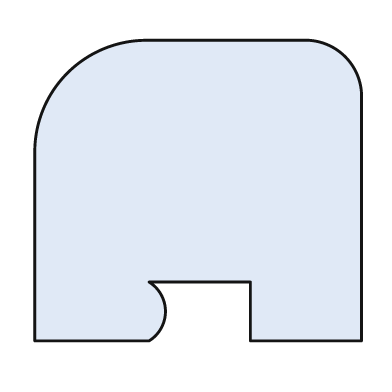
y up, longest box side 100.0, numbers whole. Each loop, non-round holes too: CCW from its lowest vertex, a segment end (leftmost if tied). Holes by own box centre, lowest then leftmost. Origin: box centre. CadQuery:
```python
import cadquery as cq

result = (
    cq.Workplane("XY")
    .moveTo(-50.0, -46.0)
    .lineTo(-15.0, -46.0)
    .threePointArc((-10.0, -37.0), (-15.0, -28.0))
    .lineTo(16.0, -28.0)
    .lineTo(16.0, -46.0)
    .lineTo(50.0, -46.0)
    .lineTo(50.0, 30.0)
    .threePointArc((45.0, 41.0), (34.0, 46.0))
    .lineTo(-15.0, 46.0)
    .threePointArc((-40.0, 36.0), (-50.0, 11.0))
    .close()
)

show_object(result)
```